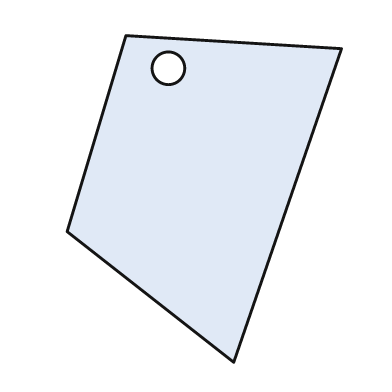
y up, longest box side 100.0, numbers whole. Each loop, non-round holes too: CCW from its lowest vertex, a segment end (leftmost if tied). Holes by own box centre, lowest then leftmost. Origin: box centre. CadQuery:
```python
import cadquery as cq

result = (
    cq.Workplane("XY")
    .moveTo(9.0, -50.0)
    .lineTo(42.0, 46.0)
    .lineTo(-24.0, 50.0)
    .lineTo(-42.0, -10.0)
    .close()
    .moveTo(-11.0, 40.0)
    .circle(5.0)
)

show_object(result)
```